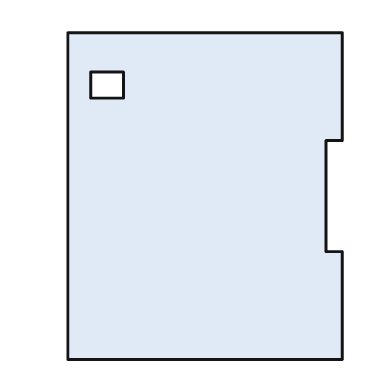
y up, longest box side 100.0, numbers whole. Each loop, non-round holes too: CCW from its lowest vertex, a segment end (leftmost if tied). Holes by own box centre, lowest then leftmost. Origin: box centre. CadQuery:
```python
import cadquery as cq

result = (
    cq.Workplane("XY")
    .moveTo(-42.0, -50.0)
    .lineTo(42.0, -50.0)
    .lineTo(42.0, -17.0)
    .lineTo(37.0, -17.0)
    .lineTo(37.0, 17.0)
    .lineTo(42.0, 17.0)
    .lineTo(42.0, 50.0)
    .lineTo(-42.0, 50.0)
    .close()
    .moveTo(-35.0, 30.0)
    .lineTo(-25.0, 30.0)
    .lineTo(-25.0, 38.0)
    .lineTo(-35.0, 38.0)
    .close()
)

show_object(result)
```